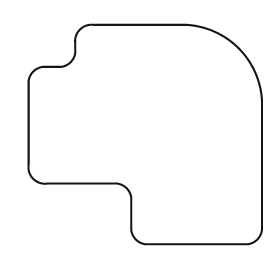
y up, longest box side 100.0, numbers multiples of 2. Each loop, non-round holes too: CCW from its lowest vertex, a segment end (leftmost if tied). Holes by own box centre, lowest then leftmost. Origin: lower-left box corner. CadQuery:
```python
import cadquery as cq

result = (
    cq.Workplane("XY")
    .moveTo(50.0, 0.0)
    .lineTo(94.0, 0.0)
    .threePointArc((98.0, 2.0), (100.0, 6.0))
    .lineTo(100.0, 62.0)
    .threePointArc((90.0, 84.0), (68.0, 94.0))
    .lineTo(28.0, 94.0)
    .threePointArc((22.0, 92.0), (20.0, 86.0))
    .lineTo(20.0, 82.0)
    .threePointArc((18.0, 78.0), (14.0, 76.0))
    .lineTo(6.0, 76.0)
    .threePointArc((2.0, 74.0), (0.0, 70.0))
    .lineTo(0.0, 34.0)
    .threePointArc((2.0, 28.0), (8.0, 26.0))
    .lineTo(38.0, 26.0)
    .threePointArc((42.0, 24.0), (44.0, 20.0))
    .lineTo(44.0, 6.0)
    .threePointArc((46.0, 2.0), (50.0, 0.0))
    .close()
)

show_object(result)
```